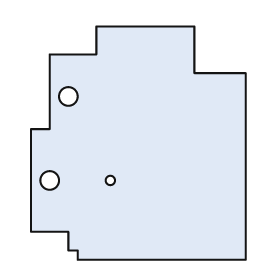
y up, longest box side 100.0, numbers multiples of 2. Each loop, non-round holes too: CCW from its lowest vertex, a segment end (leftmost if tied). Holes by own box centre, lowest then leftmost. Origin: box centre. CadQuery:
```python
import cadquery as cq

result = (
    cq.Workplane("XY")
    .moveTo(-26.0, -50.0)
    .lineTo(46.0, -50.0)
    .lineTo(46.0, 30.0)
    .lineTo(24.0, 30.0)
    .lineTo(24.0, 50.0)
    .lineTo(-18.0, 50.0)
    .lineTo(-18.0, 38.0)
    .lineTo(-38.0, 38.0)
    .lineTo(-38.0, 6.0)
    .lineTo(-46.0, 6.0)
    .lineTo(-46.0, -38.0)
    .lineTo(-30.0, -38.0)
    .lineTo(-30.0, -46.0)
    .lineTo(-26.0, -46.0)
    .close()
    .moveTo(-38.0, -16.0)
    .circle(4.0)
    .moveTo(-12.0, -16.0)
    .circle(2.0)
    .moveTo(-30.0, 20.0)
    .circle(4.0)
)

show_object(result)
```